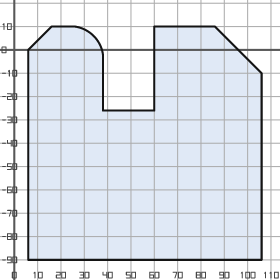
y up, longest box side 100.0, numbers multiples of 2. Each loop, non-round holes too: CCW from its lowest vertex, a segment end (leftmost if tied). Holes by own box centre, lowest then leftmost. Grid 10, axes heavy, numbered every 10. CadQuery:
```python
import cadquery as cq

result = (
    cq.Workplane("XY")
    .moveTo(6.0, -90.0)
    .lineTo(106.0, -90.0)
    .lineTo(106.0, -10.0)
    .lineTo(86.0, 10.0)
    .lineTo(60.0, 10.0)
    .lineTo(60.0, -26.0)
    .lineTo(38.0, -26.0)
    .lineTo(38.0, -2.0)
    .threePointArc((34.0, 6.0), (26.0, 10.0))
    .lineTo(16.0, 10.0)
    .lineTo(6.0, 0.0)
    .close()
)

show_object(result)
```